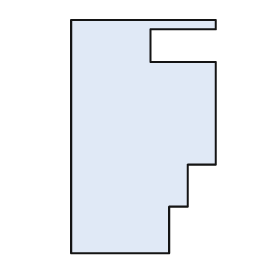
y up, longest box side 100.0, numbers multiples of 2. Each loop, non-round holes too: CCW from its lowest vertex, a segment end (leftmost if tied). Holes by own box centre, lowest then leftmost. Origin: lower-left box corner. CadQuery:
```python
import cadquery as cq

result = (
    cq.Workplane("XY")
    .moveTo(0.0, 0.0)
    .lineTo(42.0, 0.0)
    .lineTo(42.0, 20.0)
    .lineTo(50.0, 20.0)
    .lineTo(50.0, 38.0)
    .lineTo(62.0, 38.0)
    .lineTo(62.0, 82.0)
    .lineTo(34.0, 82.0)
    .lineTo(34.0, 96.0)
    .lineTo(62.0, 96.0)
    .lineTo(62.0, 100.0)
    .lineTo(0.0, 100.0)
    .close()
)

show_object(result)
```